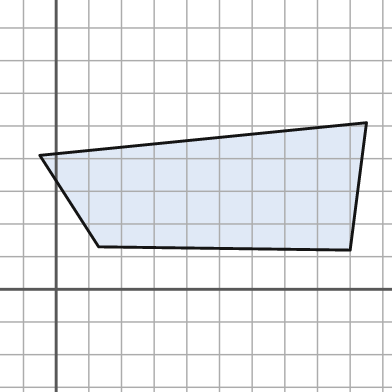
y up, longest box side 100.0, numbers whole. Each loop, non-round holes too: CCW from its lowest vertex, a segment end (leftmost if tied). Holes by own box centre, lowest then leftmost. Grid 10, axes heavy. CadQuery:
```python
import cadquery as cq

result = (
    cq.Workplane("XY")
    .moveTo(90.0, 12.0)
    .lineTo(95.0, 51.0)
    .lineTo(-5.0, 41.0)
    .lineTo(13.0, 13.0)
    .close()
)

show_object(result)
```